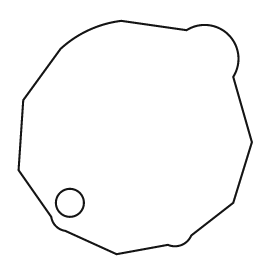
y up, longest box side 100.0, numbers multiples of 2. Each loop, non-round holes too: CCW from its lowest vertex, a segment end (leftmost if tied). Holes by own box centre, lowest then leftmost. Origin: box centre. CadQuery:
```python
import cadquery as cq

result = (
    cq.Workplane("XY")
    .moveTo(-8.0, -50.0)
    .lineTo(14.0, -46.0)
    .threePointArc((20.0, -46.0), (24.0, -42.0))
    .lineTo(42.0, -28.0)
    .lineTo(50.0, -2.0)
    .lineTo(42.0, 26.0)
    .threePointArc((40.0, 44.0), (22.0, 46.0))
    .lineTo(-6.0, 50.0)
    .threePointArc((-20.0, 46.0), (-32.0, 38.0))
    .lineTo(-48.0, 16.0)
    .lineTo(-50.0, -14.0)
    .lineTo(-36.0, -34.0)
    .threePointArc((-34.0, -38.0), (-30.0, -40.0))
    .close()
    .moveTo(-28.0, -28.0)
    .circle(6.0)
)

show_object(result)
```